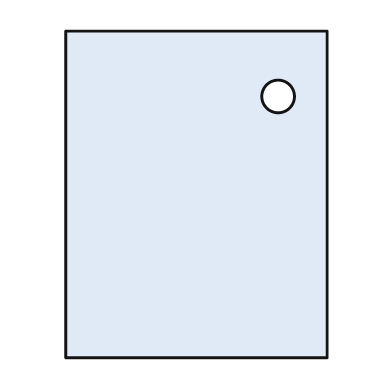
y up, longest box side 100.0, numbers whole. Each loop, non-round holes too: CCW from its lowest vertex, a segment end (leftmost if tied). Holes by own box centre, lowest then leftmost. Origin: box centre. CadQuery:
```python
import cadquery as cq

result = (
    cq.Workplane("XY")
    .moveTo(-40.0, -50.0)
    .lineTo(40.0, -50.0)
    .lineTo(40.0, 50.0)
    .lineTo(-40.0, 50.0)
    .close()
    .moveTo(25.0, 30.0)
    .circle(5.0)
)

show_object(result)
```